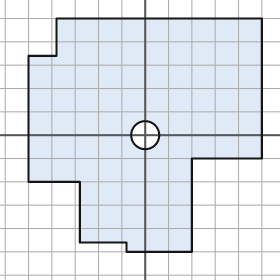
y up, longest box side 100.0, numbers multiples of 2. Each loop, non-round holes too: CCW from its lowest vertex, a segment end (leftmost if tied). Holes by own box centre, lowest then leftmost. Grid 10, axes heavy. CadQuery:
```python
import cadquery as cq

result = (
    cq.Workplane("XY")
    .moveTo(-8.0, -50.0)
    .lineTo(20.0, -50.0)
    .lineTo(20.0, -10.0)
    .lineTo(50.0, -10.0)
    .lineTo(50.0, 50.0)
    .lineTo(-38.0, 50.0)
    .lineTo(-38.0, 34.0)
    .lineTo(-50.0, 34.0)
    .lineTo(-50.0, -20.0)
    .lineTo(-28.0, -20.0)
    .lineTo(-28.0, -46.0)
    .lineTo(-8.0, -46.0)
    .close()
    .moveTo(0.0, 0.0)
    .circle(6.0)
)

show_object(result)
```